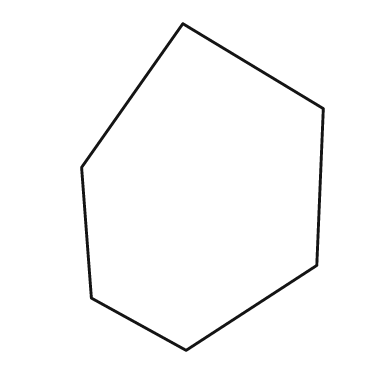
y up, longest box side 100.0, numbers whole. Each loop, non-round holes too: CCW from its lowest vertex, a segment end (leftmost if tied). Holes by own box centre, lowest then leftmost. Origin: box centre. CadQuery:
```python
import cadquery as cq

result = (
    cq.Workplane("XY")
    .moveTo(-5.0, -50.0)
    .lineTo(35.0, -24.0)
    .lineTo(37.0, 24.0)
    .lineTo(-6.0, 50.0)
    .lineTo(-37.0, 6.0)
    .lineTo(-34.0, -34.0)
    .close()
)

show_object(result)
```